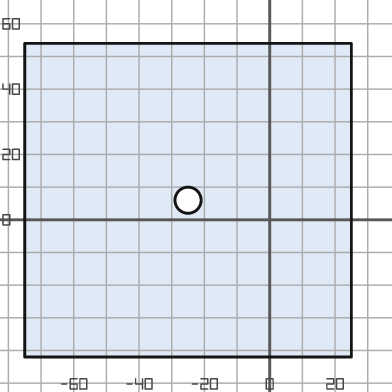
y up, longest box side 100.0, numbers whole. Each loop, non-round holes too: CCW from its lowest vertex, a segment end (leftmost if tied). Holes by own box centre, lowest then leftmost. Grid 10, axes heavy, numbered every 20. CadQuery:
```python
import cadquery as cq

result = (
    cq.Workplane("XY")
    .moveTo(-75.0, -42.0)
    .lineTo(25.0, -42.0)
    .lineTo(25.0, 54.0)
    .lineTo(-75.0, 54.0)
    .close()
    .moveTo(-25.0, 6.0)
    .circle(4.0)
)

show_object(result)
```